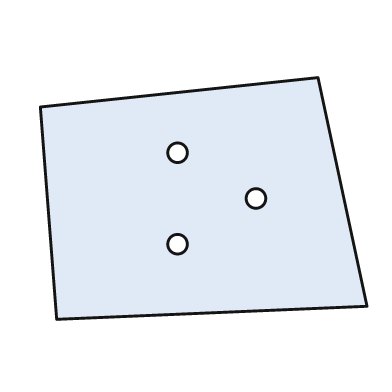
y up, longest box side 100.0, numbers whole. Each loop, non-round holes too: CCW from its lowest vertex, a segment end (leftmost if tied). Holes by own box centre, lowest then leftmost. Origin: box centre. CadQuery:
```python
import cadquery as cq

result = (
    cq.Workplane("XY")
    .moveTo(-45.0, -37.0)
    .lineTo(50.0, -33.0)
    .lineTo(35.0, 37.0)
    .lineTo(-50.0, 28.0)
    .close()
    .moveTo(-8.0, -14.0)
    .circle(3.0)
    .moveTo(16.0, 0.0)
    .circle(3.0)
    .moveTo(-8.0, 14.0)
    .circle(3.0)
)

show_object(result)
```